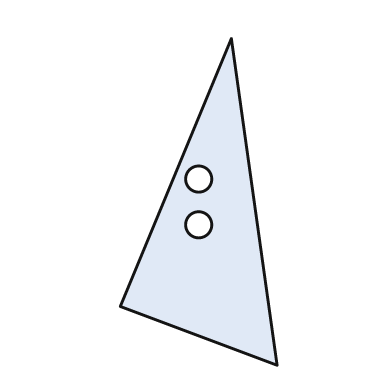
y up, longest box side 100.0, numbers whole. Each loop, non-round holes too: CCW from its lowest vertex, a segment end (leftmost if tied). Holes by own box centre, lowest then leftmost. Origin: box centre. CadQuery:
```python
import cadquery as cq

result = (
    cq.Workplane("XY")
    .moveTo(24.0, -50.0)
    .lineTo(10.0, 50.0)
    .lineTo(-24.0, -32.0)
    .close()
    .moveTo(0.0, -7.0)
    .circle(4.0)
    .moveTo(0.0, 7.0)
    .circle(4.0)
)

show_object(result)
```